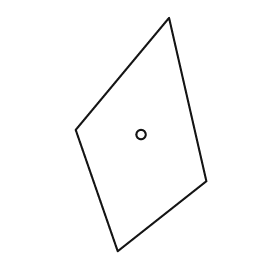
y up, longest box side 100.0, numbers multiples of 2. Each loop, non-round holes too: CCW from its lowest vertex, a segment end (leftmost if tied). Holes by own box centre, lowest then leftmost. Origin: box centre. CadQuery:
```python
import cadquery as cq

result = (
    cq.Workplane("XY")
    .moveTo(-10.0, -50.0)
    .lineTo(28.0, -20.0)
    .lineTo(12.0, 50.0)
    .lineTo(-28.0, 2.0)
    .close()
    .moveTo(0.0, 0.0)
    .circle(2.0)
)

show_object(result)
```